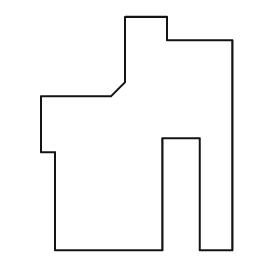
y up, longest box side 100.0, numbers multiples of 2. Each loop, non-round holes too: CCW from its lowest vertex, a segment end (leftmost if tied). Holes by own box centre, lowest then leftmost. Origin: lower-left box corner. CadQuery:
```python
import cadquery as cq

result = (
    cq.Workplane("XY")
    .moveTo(6.0, 0.0)
    .lineTo(52.0, 0.0)
    .lineTo(52.0, 48.0)
    .lineTo(68.0, 48.0)
    .lineTo(68.0, 0.0)
    .lineTo(82.0, 0.0)
    .lineTo(82.0, 90.0)
    .lineTo(54.0, 90.0)
    .lineTo(54.0, 100.0)
    .lineTo(36.0, 100.0)
    .lineTo(36.0, 72.0)
    .lineTo(30.0, 66.0)
    .lineTo(0.0, 66.0)
    .lineTo(0.0, 42.0)
    .lineTo(6.0, 42.0)
    .close()
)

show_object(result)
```